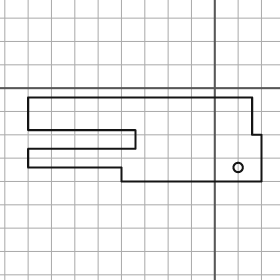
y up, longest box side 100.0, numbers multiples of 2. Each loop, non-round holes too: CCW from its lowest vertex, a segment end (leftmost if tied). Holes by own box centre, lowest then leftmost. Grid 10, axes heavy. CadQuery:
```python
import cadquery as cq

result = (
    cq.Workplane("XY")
    .moveTo(-40.0, -40.0)
    .lineTo(20.0, -40.0)
    .lineTo(20.0, -20.0)
    .lineTo(16.0, -20.0)
    .lineTo(16.0, -4.0)
    .lineTo(-80.0, -4.0)
    .lineTo(-80.0, -18.0)
    .lineTo(-34.0, -18.0)
    .lineTo(-34.0, -26.0)
    .lineTo(-80.0, -26.0)
    .lineTo(-80.0, -34.0)
    .lineTo(-40.0, -34.0)
    .close()
    .moveTo(10.0, -34.0)
    .circle(2.0)
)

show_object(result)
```